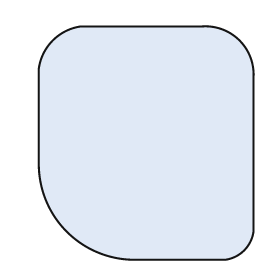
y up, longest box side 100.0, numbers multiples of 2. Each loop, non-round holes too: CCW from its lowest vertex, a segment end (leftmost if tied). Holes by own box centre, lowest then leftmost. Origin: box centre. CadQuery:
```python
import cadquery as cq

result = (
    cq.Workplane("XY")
    .moveTo(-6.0, -50.0)
    .lineTo(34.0, -50.0)
    .threePointArc((42.0, -46.0), (46.0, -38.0))
    .lineTo(46.0, 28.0)
    .threePointArc((40.0, 44.0), (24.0, 50.0))
    .lineTo(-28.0, 50.0)
    .threePointArc((-40.0, 44.0), (-46.0, 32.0))
    .lineTo(-46.0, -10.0)
    .threePointArc((-34.0, -38.0), (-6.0, -50.0))
    .close()
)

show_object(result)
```